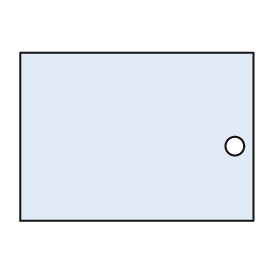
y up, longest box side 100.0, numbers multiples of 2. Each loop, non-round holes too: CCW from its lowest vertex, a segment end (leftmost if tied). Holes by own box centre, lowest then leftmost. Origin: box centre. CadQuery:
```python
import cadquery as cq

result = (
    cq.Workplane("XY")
    .moveTo(-50.0, -36.0)
    .lineTo(50.0, -36.0)
    .lineTo(50.0, 36.0)
    .lineTo(-50.0, 36.0)
    .close()
    .moveTo(42.0, -4.0)
    .circle(4.0)
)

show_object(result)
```